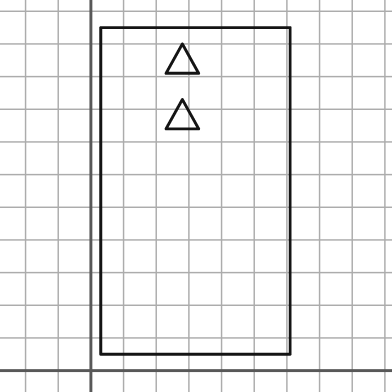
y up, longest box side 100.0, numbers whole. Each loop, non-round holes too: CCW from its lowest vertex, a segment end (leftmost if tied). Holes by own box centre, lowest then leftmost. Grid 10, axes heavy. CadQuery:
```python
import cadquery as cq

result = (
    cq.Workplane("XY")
    .moveTo(3.0, 5.0)
    .lineTo(61.0, 5.0)
    .lineTo(61.0, 105.0)
    .lineTo(3.0, 105.0)
    .close()
    .moveTo(23.0, 74.0)
    .lineTo(33.0, 74.0)
    .lineTo(28.0, 83.0)
    .close()
    .moveTo(23.0, 91.0)
    .lineTo(33.0, 91.0)
    .lineTo(28.0, 100.0)
    .close()
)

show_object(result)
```